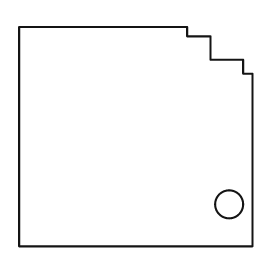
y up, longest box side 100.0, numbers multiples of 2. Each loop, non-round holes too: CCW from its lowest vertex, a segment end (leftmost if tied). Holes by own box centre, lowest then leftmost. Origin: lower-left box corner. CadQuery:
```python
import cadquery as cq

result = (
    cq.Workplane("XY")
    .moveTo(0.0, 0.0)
    .lineTo(100.0, 0.0)
    .lineTo(100.0, 74.0)
    .lineTo(96.0, 74.0)
    .lineTo(96.0, 80.0)
    .lineTo(82.0, 80.0)
    .lineTo(82.0, 90.0)
    .lineTo(72.0, 90.0)
    .lineTo(72.0, 94.0)
    .lineTo(0.0, 94.0)
    .close()
    .moveTo(90.0, 18.0)
    .circle(6.0)
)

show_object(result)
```